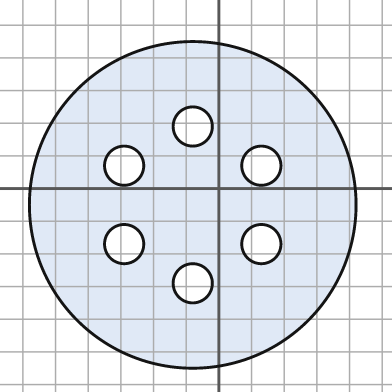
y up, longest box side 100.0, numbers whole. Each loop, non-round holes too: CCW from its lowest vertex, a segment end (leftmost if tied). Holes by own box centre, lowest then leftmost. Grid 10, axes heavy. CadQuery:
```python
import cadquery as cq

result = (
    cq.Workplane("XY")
    .moveTo(-8.0, -5.0)
    .circle(50.0)
    .moveTo(-8.0, -29.0)
    .circle(6.0)
    .moveTo(-29.0, -17.0)
    .circle(6.0)
    .moveTo(13.0, -17.0)
    .circle(6.0)
    .moveTo(-29.0, 7.0)
    .circle(6.0)
    .moveTo(13.0, 7.0)
    .circle(6.0)
    .moveTo(-8.0, 19.0)
    .circle(6.0)
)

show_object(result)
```